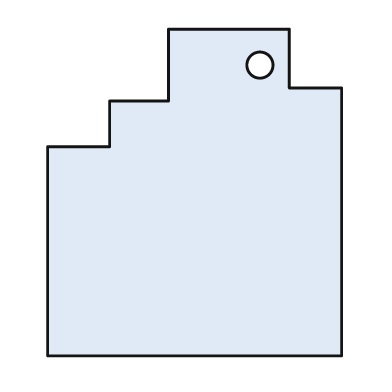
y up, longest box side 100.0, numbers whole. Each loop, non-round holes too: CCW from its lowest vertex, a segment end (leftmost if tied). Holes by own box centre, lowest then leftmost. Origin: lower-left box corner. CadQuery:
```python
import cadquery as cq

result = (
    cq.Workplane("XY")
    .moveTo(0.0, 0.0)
    .lineTo(90.0, 0.0)
    .lineTo(90.0, 82.0)
    .lineTo(74.0, 82.0)
    .lineTo(74.0, 100.0)
    .lineTo(37.0, 100.0)
    .lineTo(37.0, 78.0)
    .lineTo(19.0, 78.0)
    .lineTo(19.0, 64.0)
    .lineTo(0.0, 64.0)
    .close()
    .moveTo(65.0, 89.0)
    .circle(4.0)
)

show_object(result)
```